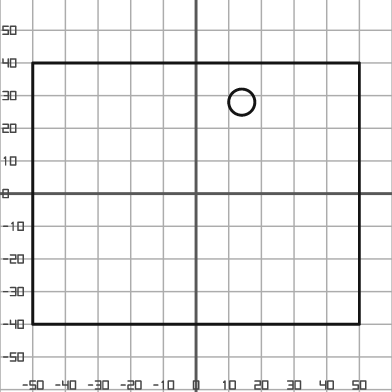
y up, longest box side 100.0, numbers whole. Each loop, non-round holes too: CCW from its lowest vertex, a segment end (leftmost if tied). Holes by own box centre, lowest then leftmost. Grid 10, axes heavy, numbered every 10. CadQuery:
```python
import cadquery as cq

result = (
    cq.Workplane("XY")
    .moveTo(-50.0, -40.0)
    .lineTo(50.0, -40.0)
    .lineTo(50.0, 40.0)
    .lineTo(-50.0, 40.0)
    .close()
    .moveTo(14.0, 28.0)
    .circle(4.0)
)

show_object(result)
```